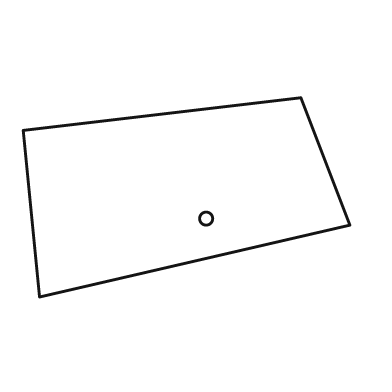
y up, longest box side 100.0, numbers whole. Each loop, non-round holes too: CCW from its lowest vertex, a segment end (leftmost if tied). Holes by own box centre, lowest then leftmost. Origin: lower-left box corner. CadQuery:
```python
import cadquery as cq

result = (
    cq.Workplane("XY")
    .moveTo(5.0, 0.0)
    .lineTo(100.0, 22.0)
    .lineTo(85.0, 61.0)
    .lineTo(0.0, 51.0)
    .close()
    .moveTo(56.0, 24.0)
    .circle(2.0)
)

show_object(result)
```